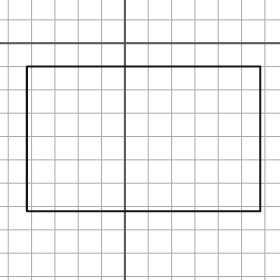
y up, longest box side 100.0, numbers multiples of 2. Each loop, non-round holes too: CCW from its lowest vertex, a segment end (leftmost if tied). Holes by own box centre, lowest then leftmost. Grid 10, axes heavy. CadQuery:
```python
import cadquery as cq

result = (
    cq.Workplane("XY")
    .moveTo(-42.0, -72.0)
    .lineTo(58.0, -72.0)
    .lineTo(58.0, -10.0)
    .lineTo(-42.0, -10.0)
    .close()
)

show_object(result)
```